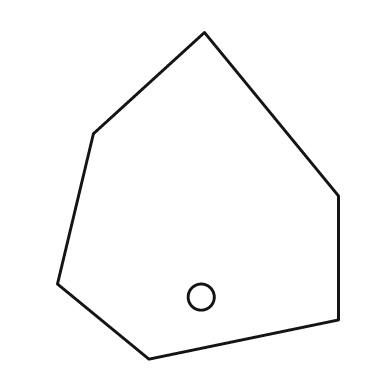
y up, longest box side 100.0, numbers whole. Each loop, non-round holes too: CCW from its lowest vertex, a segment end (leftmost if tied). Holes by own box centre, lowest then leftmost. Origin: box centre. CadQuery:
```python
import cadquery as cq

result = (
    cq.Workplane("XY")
    .moveTo(-15.0, -50.0)
    .lineTo(43.0, -38.0)
    .lineTo(43.0, 0.0)
    .lineTo(2.0, 50.0)
    .lineTo(-32.0, 19.0)
    .lineTo(-43.0, -27.0)
    .close()
    .moveTo(1.0, -31.0)
    .circle(4.0)
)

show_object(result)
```